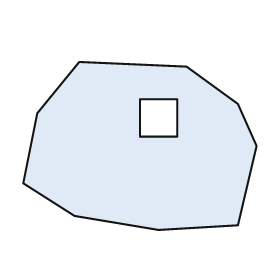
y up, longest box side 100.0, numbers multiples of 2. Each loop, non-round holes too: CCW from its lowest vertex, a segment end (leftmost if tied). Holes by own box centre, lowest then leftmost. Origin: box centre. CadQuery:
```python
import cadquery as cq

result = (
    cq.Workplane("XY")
    .moveTo(8.0, -36.0)
    .lineTo(42.0, -34.0)
    .lineTo(50.0, 0.0)
    .lineTo(42.0, 18.0)
    .lineTo(20.0, 34.0)
    .lineTo(-26.0, 36.0)
    .lineTo(-44.0, 14.0)
    .lineTo(-50.0, -16.0)
    .lineTo(-28.0, -30.0)
    .close()
    .moveTo(0.0, 4.0)
    .lineTo(16.0, 4.0)
    .lineTo(16.0, 20.0)
    .lineTo(0.0, 20.0)
    .close()
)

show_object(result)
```